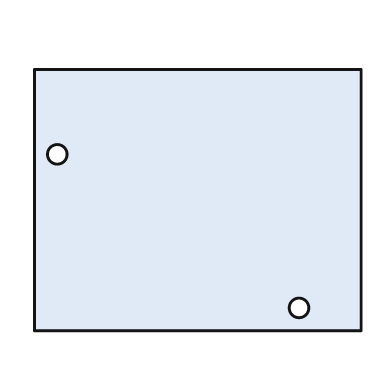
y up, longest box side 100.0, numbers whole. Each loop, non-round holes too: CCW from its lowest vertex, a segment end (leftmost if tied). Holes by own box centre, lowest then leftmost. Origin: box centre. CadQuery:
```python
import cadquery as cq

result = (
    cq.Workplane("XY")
    .moveTo(-50.0, -40.0)
    .lineTo(50.0, -40.0)
    .lineTo(50.0, 40.0)
    .lineTo(-50.0, 40.0)
    .close()
    .moveTo(31.0, -33.0)
    .circle(3.0)
    .moveTo(-43.0, 14.0)
    .circle(3.0)
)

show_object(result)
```